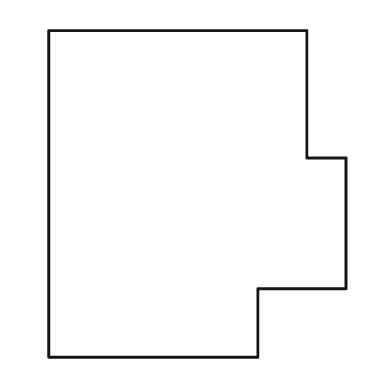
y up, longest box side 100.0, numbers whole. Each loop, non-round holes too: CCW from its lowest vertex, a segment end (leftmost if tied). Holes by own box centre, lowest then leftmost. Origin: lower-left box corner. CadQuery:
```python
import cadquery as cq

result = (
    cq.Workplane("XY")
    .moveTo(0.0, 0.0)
    .lineTo(64.0, 0.0)
    .lineTo(64.0, 21.0)
    .lineTo(91.0, 21.0)
    .lineTo(91.0, 61.0)
    .lineTo(79.0, 61.0)
    .lineTo(79.0, 100.0)
    .lineTo(0.0, 100.0)
    .close()
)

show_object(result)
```